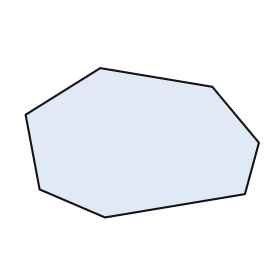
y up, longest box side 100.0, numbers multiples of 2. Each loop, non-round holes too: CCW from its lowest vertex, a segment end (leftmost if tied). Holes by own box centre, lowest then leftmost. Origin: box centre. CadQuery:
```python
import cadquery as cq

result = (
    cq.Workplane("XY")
    .moveTo(-16.0, -32.0)
    .lineTo(44.0, -22.0)
    .lineTo(50.0, 0.0)
    .lineTo(30.0, 24.0)
    .lineTo(-18.0, 32.0)
    .lineTo(-50.0, 12.0)
    .lineTo(-44.0, -20.0)
    .close()
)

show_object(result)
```